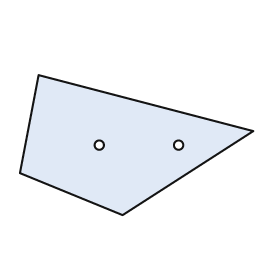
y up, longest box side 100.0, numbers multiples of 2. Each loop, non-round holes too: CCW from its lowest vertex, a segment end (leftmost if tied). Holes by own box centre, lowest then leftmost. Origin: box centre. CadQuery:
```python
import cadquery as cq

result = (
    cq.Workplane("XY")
    .moveTo(-6.0, -30.0)
    .lineTo(50.0, 6.0)
    .lineTo(-42.0, 30.0)
    .lineTo(-50.0, -12.0)
    .close()
    .moveTo(-16.0, 0.0)
    .circle(2.0)
    .moveTo(18.0, 0.0)
    .circle(2.0)
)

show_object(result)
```